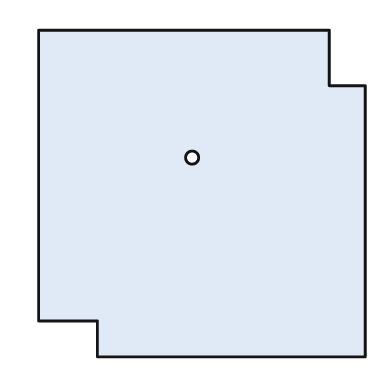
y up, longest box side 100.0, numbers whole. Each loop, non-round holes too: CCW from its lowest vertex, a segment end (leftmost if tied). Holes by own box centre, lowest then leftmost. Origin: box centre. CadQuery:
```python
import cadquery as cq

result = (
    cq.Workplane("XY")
    .moveTo(-32.0, -50.0)
    .lineTo(50.0, -50.0)
    .lineTo(50.0, 33.0)
    .lineTo(39.0, 33.0)
    .lineTo(39.0, 50.0)
    .lineTo(-50.0, 50.0)
    .lineTo(-50.0, -39.0)
    .lineTo(-32.0, -39.0)
    .close()
    .moveTo(-3.0, 11.0)
    .circle(2.0)
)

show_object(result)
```